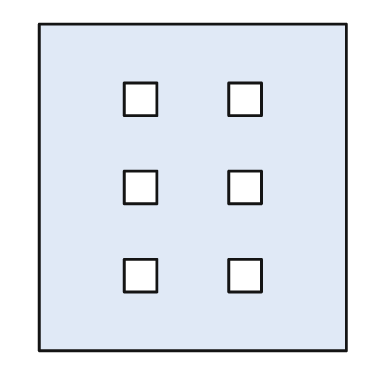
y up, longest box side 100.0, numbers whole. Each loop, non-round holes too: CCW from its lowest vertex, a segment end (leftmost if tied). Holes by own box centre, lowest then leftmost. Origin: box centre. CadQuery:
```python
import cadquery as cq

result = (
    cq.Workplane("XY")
    .moveTo(-47.0, -50.0)
    .lineTo(47.0, -50.0)
    .lineTo(47.0, 50.0)
    .lineTo(-47.0, 50.0)
    .close()
    .moveTo(-21.0, -32.0)
    .lineTo(-11.0, -32.0)
    .lineTo(-11.0, -22.0)
    .lineTo(-21.0, -22.0)
    .close()
    .moveTo(11.0, -32.0)
    .lineTo(21.0, -32.0)
    .lineTo(21.0, -22.0)
    .lineTo(11.0, -22.0)
    .close()
    .moveTo(-21.0, -5.0)
    .lineTo(-11.0, -5.0)
    .lineTo(-11.0, 5.0)
    .lineTo(-21.0, 5.0)
    .close()
    .moveTo(11.0, -5.0)
    .lineTo(21.0, -5.0)
    .lineTo(21.0, 5.0)
    .lineTo(11.0, 5.0)
    .close()
    .moveTo(-21.0, 22.0)
    .lineTo(-11.0, 22.0)
    .lineTo(-11.0, 32.0)
    .lineTo(-21.0, 32.0)
    .close()
    .moveTo(11.0, 22.0)
    .lineTo(21.0, 22.0)
    .lineTo(21.0, 32.0)
    .lineTo(11.0, 32.0)
    .close()
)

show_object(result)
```